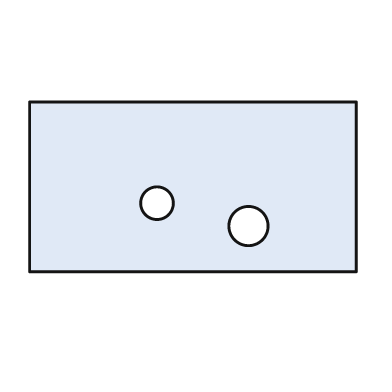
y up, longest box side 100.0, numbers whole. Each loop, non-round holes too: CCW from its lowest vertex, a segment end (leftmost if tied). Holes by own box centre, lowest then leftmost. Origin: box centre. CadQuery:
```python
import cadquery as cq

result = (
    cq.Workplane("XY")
    .moveTo(-50.0, -26.0)
    .lineTo(50.0, -26.0)
    .lineTo(50.0, 26.0)
    .lineTo(-50.0, 26.0)
    .close()
    .moveTo(17.0, -12.0)
    .circle(6.0)
    .moveTo(-11.0, -5.0)
    .circle(5.0)
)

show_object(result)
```